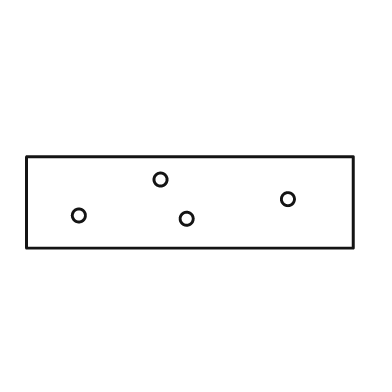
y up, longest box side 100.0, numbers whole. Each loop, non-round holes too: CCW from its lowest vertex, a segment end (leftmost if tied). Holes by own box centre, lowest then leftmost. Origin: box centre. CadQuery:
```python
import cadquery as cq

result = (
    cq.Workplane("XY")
    .moveTo(-50.0, -14.0)
    .lineTo(50.0, -14.0)
    .lineTo(50.0, 14.0)
    .lineTo(-50.0, 14.0)
    .close()
    .moveTo(-1.0, -5.0)
    .circle(2.0)
    .moveTo(-34.0, -4.0)
    .circle(2.0)
    .moveTo(30.0, 1.0)
    .circle(2.0)
    .moveTo(-9.0, 7.0)
    .circle(2.0)
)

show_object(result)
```